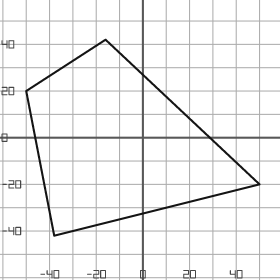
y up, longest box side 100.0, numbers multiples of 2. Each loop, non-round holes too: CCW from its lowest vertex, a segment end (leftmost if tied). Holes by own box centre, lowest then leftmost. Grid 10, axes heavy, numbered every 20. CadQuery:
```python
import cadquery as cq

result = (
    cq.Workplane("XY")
    .moveTo(-38.0, -42.0)
    .lineTo(50.0, -20.0)
    .lineTo(-16.0, 42.0)
    .lineTo(-50.0, 20.0)
    .close()
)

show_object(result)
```